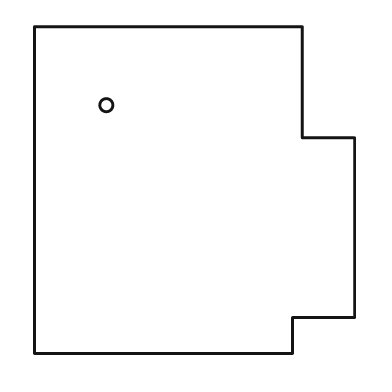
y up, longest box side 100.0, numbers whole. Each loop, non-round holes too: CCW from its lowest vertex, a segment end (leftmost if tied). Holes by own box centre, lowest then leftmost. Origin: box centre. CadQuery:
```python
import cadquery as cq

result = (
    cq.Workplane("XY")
    .moveTo(-49.0, -50.0)
    .lineTo(30.0, -50.0)
    .lineTo(30.0, -39.0)
    .lineTo(49.0, -39.0)
    .lineTo(49.0, 16.0)
    .lineTo(33.0, 16.0)
    .lineTo(33.0, 50.0)
    .lineTo(-49.0, 50.0)
    .close()
    .moveTo(-27.0, 26.0)
    .circle(2.0)
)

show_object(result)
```